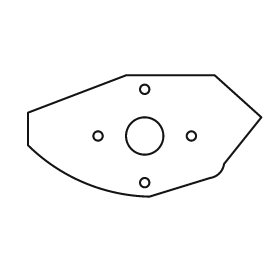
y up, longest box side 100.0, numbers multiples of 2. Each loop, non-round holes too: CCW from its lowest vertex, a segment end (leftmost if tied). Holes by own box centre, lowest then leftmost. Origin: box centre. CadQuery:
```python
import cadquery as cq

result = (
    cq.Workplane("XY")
    .moveTo(2.0, -26.0)
    .lineTo(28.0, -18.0)
    .threePointArc((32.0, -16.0), (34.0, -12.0))
    .lineTo(50.0, 8.0)
    .lineTo(30.0, 26.0)
    .lineTo(-8.0, 26.0)
    .lineTo(-50.0, 10.0)
    .lineTo(-50.0, -4.0)
    .threePointArc((-26.0, -20.0), (2.0, -26.0))
    .close()
    .moveTo(0.0, -20.0)
    .circle(2.0)
    .moveTo(-20.0, 0.0)
    .circle(2.0)
    .moveTo(0.0, 0.0)
    .circle(8.0)
    .moveTo(20.0, 0.0)
    .circle(2.0)
    .moveTo(0.0, 20.0)
    .circle(2.0)
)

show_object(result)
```